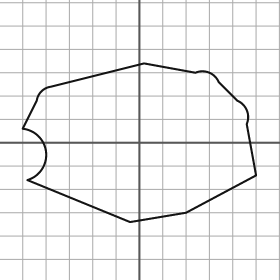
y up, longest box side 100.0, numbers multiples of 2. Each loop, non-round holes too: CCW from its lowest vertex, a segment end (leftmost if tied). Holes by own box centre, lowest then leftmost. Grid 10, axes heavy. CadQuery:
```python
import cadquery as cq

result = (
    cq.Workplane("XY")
    .moveTo(-4.0, -34.0)
    .lineTo(20.0, -30.0)
    .lineTo(50.0, -14.0)
    .lineTo(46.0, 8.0)
    .threePointArc((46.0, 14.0), (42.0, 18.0))
    .lineTo(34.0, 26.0)
    .threePointArc((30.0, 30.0), (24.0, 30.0))
    .lineTo(2.0, 34.0)
    .lineTo(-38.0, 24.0)
    .threePointArc((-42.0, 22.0), (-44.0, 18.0))
    .lineTo(-50.0, 6.0)
    .threePointArc((-40.0, -4.0), (-48.0, -16.0))
    .close()
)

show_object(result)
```